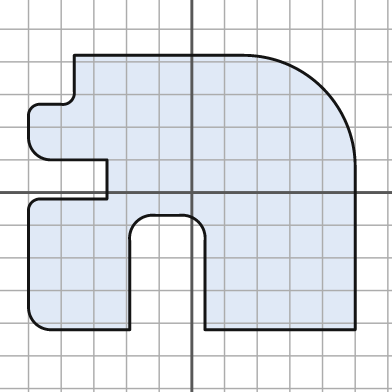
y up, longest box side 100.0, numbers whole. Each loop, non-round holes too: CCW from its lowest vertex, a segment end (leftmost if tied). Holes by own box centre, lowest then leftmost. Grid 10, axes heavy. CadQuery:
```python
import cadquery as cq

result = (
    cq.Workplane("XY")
    .moveTo(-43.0, -42.0)
    .lineTo(-19.0, -42.0)
    .lineTo(-19.0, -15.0)
    .threePointArc((-17.0, -9.0), (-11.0, -7.0))
    .lineTo(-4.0, -7.0)
    .threePointArc((2.0, -9.0), (4.0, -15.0))
    .lineTo(4.0, -42.0)
    .lineTo(50.0, -42.0)
    .lineTo(50.0, 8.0)
    .threePointArc((40.0, 32.0), (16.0, 42.0))
    .lineTo(-36.0, 42.0)
    .lineTo(-36.0, 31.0)
    .threePointArc((-37.0, 28.0), (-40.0, 27.0))
    .lineTo(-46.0, 27.0)
    .threePointArc((-49.0, 26.0), (-50.0, 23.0))
    .lineTo(-50.0, 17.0)
    .threePointArc((-48.0, 12.0), (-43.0, 10.0))
    .lineTo(-26.0, 10.0)
    .lineTo(-26.0, -2.0)
    .lineTo(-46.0, -2.0)
    .threePointArc((-49.0, -3.0), (-50.0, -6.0))
    .lineTo(-50.0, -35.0)
    .threePointArc((-48.0, -40.0), (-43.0, -42.0))
    .close()
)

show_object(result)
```